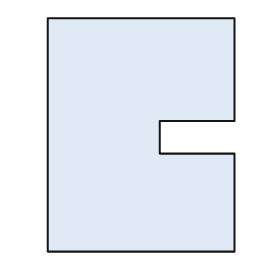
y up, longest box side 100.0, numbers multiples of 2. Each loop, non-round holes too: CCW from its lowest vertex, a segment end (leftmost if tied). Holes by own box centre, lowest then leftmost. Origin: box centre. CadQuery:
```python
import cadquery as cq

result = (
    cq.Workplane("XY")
    .moveTo(-40.0, -50.0)
    .lineTo(40.0, -50.0)
    .lineTo(40.0, -8.0)
    .lineTo(8.0, -8.0)
    .lineTo(8.0, 6.0)
    .lineTo(40.0, 6.0)
    .lineTo(40.0, 50.0)
    .lineTo(-40.0, 50.0)
    .close()
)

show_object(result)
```